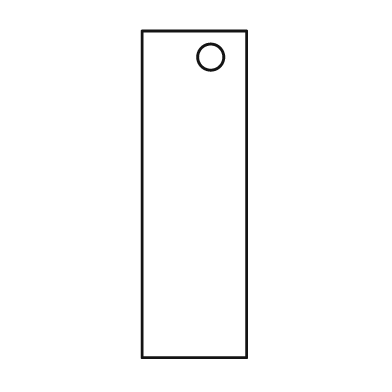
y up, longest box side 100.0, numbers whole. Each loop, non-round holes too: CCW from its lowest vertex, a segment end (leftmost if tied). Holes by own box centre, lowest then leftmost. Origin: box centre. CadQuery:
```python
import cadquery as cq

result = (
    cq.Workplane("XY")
    .moveTo(-16.0, -50.0)
    .lineTo(16.0, -50.0)
    .lineTo(16.0, 50.0)
    .lineTo(-16.0, 50.0)
    .close()
    .moveTo(5.0, 42.0)
    .circle(4.0)
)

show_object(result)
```